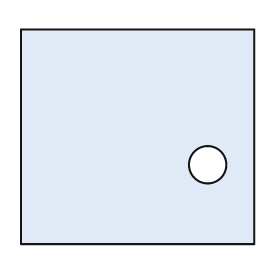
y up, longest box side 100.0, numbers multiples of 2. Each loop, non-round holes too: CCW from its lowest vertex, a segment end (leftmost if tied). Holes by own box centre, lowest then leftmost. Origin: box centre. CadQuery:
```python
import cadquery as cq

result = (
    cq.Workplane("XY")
    .moveTo(-50.0, -46.0)
    .lineTo(50.0, -46.0)
    .lineTo(50.0, 46.0)
    .lineTo(-50.0, 46.0)
    .close()
    .moveTo(30.0, -12.0)
    .circle(8.0)
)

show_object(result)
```